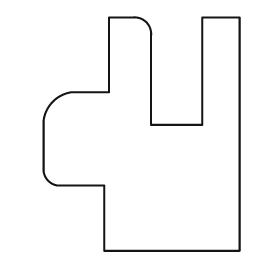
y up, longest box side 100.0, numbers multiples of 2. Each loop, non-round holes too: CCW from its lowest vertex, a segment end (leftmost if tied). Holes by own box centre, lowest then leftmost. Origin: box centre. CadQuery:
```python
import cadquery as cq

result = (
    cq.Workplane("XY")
    .moveTo(-16.0, -50.0)
    .lineTo(42.0, -50.0)
    .lineTo(42.0, 50.0)
    .lineTo(26.0, 50.0)
    .lineTo(26.0, 4.0)
    .lineTo(4.0, 4.0)
    .lineTo(4.0, 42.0)
    .threePointArc((2.0, 48.0), (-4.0, 50.0))
    .lineTo(-14.0, 50.0)
    .lineTo(-14.0, 18.0)
    .lineTo(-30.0, 18.0)
    .threePointArc((-38.0, 14.0), (-42.0, 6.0))
    .lineTo(-42.0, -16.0)
    .threePointArc((-40.0, -20.0), (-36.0, -22.0))
    .lineTo(-16.0, -22.0)
    .close()
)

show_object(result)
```